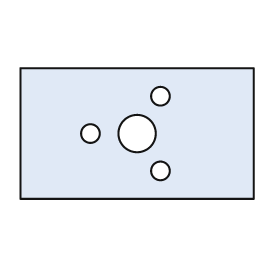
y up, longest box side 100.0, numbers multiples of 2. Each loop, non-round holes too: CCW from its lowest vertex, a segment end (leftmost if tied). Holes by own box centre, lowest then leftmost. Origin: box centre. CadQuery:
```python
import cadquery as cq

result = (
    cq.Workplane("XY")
    .moveTo(-50.0, -28.0)
    .lineTo(50.0, -28.0)
    .lineTo(50.0, 28.0)
    .lineTo(-50.0, 28.0)
    .close()
    .moveTo(10.0, -16.0)
    .circle(4.0)
    .moveTo(-20.0, 0.0)
    .circle(4.0)
    .moveTo(0.0, 0.0)
    .circle(8.0)
    .moveTo(10.0, 16.0)
    .circle(4.0)
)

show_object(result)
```